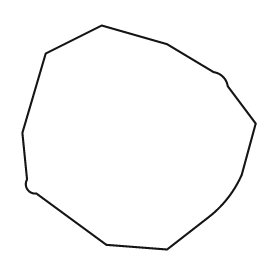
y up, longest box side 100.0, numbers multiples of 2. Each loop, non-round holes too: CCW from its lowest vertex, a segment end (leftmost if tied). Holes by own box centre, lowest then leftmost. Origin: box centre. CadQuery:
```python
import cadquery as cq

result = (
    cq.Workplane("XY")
    .moveTo(12.0, -48.0)
    .lineTo(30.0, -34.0)
    .threePointArc((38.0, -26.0), (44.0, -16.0))
    .lineTo(50.0, 6.0)
    .lineTo(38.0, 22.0)
    .threePointArc((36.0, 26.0), (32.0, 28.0))
    .lineTo(12.0, 40.0)
    .lineTo(-16.0, 48.0)
    .lineTo(-40.0, 36.0)
    .lineTo(-50.0, 2.0)
    .lineTo(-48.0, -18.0)
    .threePointArc((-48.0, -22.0), (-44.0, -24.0))
    .lineTo(-14.0, -46.0)
    .close()
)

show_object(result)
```